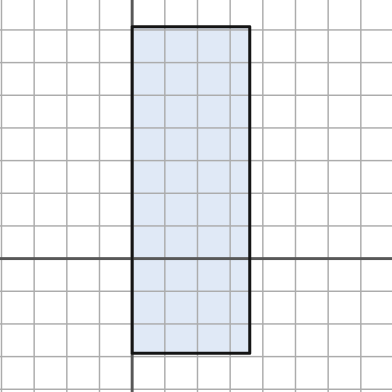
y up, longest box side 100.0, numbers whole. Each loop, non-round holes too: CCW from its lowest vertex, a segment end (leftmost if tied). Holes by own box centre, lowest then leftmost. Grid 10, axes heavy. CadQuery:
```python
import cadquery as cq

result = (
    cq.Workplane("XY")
    .moveTo(0.0, -29.0)
    .lineTo(36.0, -29.0)
    .lineTo(36.0, 71.0)
    .lineTo(0.0, 71.0)
    .close()
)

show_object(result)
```